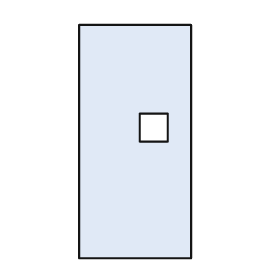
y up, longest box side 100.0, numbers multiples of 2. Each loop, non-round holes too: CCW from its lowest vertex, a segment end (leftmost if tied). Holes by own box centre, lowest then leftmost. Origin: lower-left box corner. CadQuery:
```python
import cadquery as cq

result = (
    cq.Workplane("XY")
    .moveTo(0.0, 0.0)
    .lineTo(48.0, 0.0)
    .lineTo(48.0, 100.0)
    .lineTo(0.0, 100.0)
    .close()
    .moveTo(26.0, 50.0)
    .lineTo(38.0, 50.0)
    .lineTo(38.0, 62.0)
    .lineTo(26.0, 62.0)
    .close()
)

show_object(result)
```